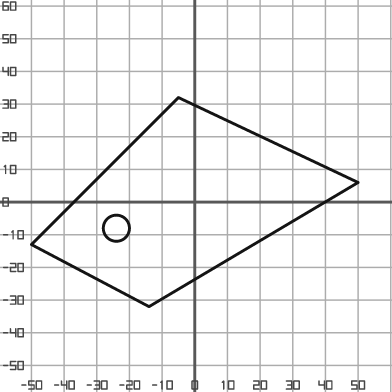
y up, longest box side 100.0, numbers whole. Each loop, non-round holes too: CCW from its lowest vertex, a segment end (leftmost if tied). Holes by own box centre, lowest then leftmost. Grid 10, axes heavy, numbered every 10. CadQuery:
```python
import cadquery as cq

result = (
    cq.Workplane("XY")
    .moveTo(-14.0, -32.0)
    .lineTo(50.0, 6.0)
    .lineTo(-5.0, 32.0)
    .lineTo(-50.0, -13.0)
    .close()
    .moveTo(-24.0, -8.0)
    .circle(4.0)
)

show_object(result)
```